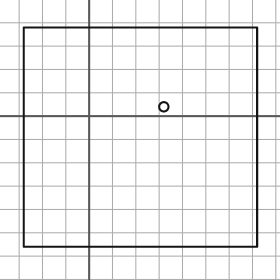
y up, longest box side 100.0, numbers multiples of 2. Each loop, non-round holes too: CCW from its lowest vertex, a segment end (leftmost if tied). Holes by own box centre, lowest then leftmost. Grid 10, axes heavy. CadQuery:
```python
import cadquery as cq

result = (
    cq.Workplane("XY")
    .moveTo(-28.0, -56.0)
    .lineTo(72.0, -56.0)
    .lineTo(72.0, 38.0)
    .lineTo(-28.0, 38.0)
    .close()
    .moveTo(32.0, 4.0)
    .circle(2.0)
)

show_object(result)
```